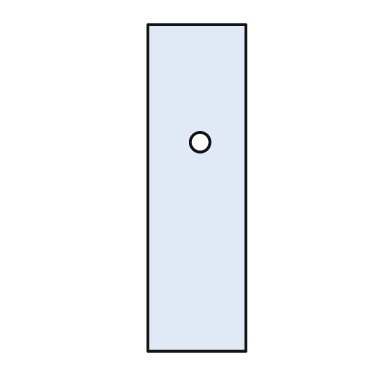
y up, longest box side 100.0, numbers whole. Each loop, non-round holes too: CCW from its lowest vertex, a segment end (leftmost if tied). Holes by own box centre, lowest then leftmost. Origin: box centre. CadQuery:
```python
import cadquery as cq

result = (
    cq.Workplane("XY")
    .moveTo(-15.0, -50.0)
    .lineTo(15.0, -50.0)
    .lineTo(15.0, 50.0)
    .lineTo(-15.0, 50.0)
    .close()
    .moveTo(1.0, 14.0)
    .circle(3.0)
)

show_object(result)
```